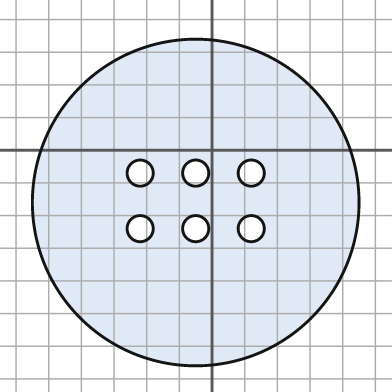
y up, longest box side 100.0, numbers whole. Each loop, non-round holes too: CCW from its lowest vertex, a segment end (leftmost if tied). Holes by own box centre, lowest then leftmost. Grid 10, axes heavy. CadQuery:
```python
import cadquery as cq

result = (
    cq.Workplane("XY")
    .moveTo(-5.0, -16.0)
    .circle(50.0)
    .moveTo(-22.0, -24.0)
    .circle(4.0)
    .moveTo(-5.0, -24.0)
    .circle(4.0)
    .moveTo(12.0, -24.0)
    .circle(4.0)
    .moveTo(-22.0, -7.0)
    .circle(4.0)
    .moveTo(-5.0, -7.0)
    .circle(4.0)
    .moveTo(12.0, -7.0)
    .circle(4.0)
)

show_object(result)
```